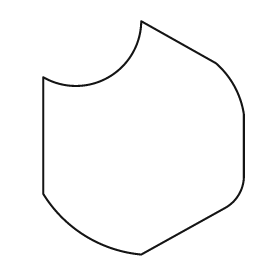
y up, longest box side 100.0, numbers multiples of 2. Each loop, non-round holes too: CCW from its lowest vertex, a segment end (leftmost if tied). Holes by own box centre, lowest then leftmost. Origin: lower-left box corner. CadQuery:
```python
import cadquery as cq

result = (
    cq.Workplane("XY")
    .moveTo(42.0, 0.0)
    .lineTo(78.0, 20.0)
    .threePointArc((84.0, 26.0), (86.0, 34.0))
    .lineTo(86.0, 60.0)
    .threePointArc((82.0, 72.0), (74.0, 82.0))
    .lineTo(42.0, 100.0)
    .threePointArc((28.0, 76.0), (0.0, 76.0))
    .lineTo(0.0, 26.0)
    .threePointArc((18.0, 8.0), (42.0, 0.0))
    .close()
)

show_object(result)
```